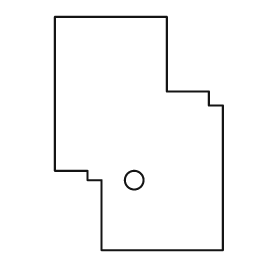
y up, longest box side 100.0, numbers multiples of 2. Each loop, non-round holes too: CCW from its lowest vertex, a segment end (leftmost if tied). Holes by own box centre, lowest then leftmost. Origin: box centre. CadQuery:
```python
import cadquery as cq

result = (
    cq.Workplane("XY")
    .moveTo(-16.0, -50.0)
    .lineTo(36.0, -50.0)
    .lineTo(36.0, 12.0)
    .lineTo(30.0, 12.0)
    .lineTo(30.0, 18.0)
    .lineTo(12.0, 18.0)
    .lineTo(12.0, 50.0)
    .lineTo(-36.0, 50.0)
    .lineTo(-36.0, -16.0)
    .lineTo(-22.0, -16.0)
    .lineTo(-22.0, -20.0)
    .lineTo(-16.0, -20.0)
    .close()
    .moveTo(-2.0, -20.0)
    .circle(4.0)
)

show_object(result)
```